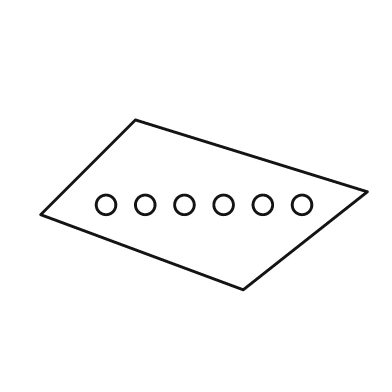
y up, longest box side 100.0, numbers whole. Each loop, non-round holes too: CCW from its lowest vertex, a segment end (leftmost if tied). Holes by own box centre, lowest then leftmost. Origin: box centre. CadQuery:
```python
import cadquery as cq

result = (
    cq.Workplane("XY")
    .moveTo(12.0, -26.0)
    .lineTo(50.0, 4.0)
    .lineTo(-21.0, 26.0)
    .lineTo(-50.0, -3.0)
    .close()
    .moveTo(-30.0, 0.0)
    .circle(3.0)
    .moveTo(-18.0, 0.0)
    .circle(3.0)
    .moveTo(-6.0, 0.0)
    .circle(3.0)
    .moveTo(6.0, 0.0)
    .circle(3.0)
    .moveTo(18.0, 0.0)
    .circle(3.0)
    .moveTo(30.0, 0.0)
    .circle(3.0)
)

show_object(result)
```